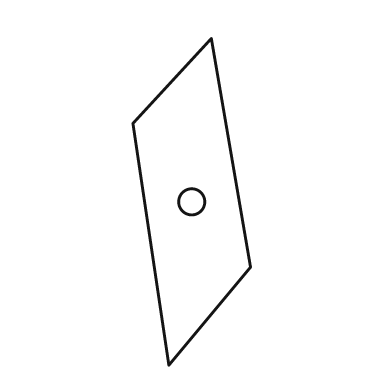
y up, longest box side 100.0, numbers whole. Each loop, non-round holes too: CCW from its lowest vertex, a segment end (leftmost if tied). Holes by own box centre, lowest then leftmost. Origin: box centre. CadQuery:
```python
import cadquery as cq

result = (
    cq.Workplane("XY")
    .moveTo(-7.0, -50.0)
    .lineTo(18.0, -20.0)
    .lineTo(6.0, 50.0)
    .lineTo(-18.0, 24.0)
    .close()
    .moveTo(0.0, 0.0)
    .circle(4.0)
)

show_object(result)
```